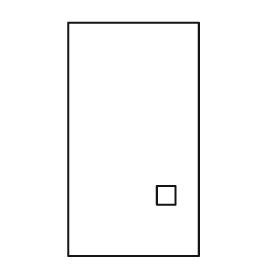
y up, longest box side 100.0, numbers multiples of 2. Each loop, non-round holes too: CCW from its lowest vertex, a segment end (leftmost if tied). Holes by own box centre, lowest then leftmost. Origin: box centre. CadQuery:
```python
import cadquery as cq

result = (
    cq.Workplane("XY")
    .moveTo(-28.0, -50.0)
    .lineTo(28.0, -50.0)
    .lineTo(28.0, 50.0)
    .lineTo(-28.0, 50.0)
    .close()
    .moveTo(10.0, -28.0)
    .lineTo(18.0, -28.0)
    .lineTo(18.0, -20.0)
    .lineTo(10.0, -20.0)
    .close()
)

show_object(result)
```